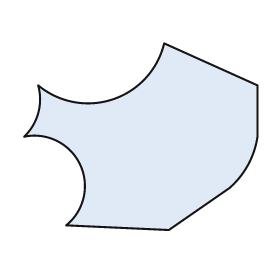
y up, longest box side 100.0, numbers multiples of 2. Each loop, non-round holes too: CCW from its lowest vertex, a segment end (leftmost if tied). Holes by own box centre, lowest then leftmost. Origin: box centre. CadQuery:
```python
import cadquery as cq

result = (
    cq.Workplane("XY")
    .moveTo(12.0, -40.0)
    .lineTo(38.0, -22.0)
    .threePointArc((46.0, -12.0), (50.0, 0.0))
    .lineTo(50.0, 22.0)
    .lineTo(10.0, 40.0)
    .threePointArc((-12.0, 16.0), (-44.0, 22.0))
    .threePointArc((-44.0, 10.0), (-50.0, 0.0))
    .threePointArc((-26.0, -12.0), (-32.0, -38.0))
    .close()
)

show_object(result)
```